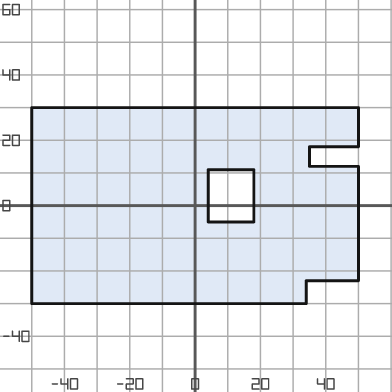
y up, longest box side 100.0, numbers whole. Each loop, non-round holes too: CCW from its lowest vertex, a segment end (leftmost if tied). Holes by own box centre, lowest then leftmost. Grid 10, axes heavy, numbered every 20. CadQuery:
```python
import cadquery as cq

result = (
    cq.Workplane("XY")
    .moveTo(-50.0, -30.0)
    .lineTo(34.0, -30.0)
    .lineTo(34.0, -23.0)
    .lineTo(50.0, -23.0)
    .lineTo(50.0, 12.0)
    .lineTo(35.0, 12.0)
    .lineTo(35.0, 18.0)
    .lineTo(50.0, 18.0)
    .lineTo(50.0, 30.0)
    .lineTo(-50.0, 30.0)
    .close()
    .moveTo(4.0, -5.0)
    .lineTo(18.0, -5.0)
    .lineTo(18.0, 11.0)
    .lineTo(4.0, 11.0)
    .close()
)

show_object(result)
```